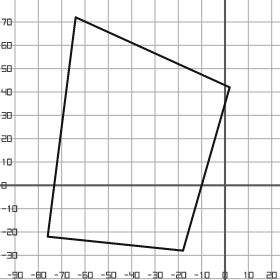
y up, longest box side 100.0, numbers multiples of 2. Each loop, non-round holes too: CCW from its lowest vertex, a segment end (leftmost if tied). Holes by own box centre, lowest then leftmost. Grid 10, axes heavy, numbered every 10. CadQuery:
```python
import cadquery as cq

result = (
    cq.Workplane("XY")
    .moveTo(-18.0, -28.0)
    .lineTo(2.0, 42.0)
    .lineTo(-64.0, 72.0)
    .lineTo(-76.0, -22.0)
    .close()
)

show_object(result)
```